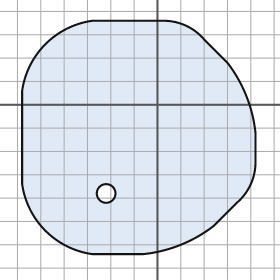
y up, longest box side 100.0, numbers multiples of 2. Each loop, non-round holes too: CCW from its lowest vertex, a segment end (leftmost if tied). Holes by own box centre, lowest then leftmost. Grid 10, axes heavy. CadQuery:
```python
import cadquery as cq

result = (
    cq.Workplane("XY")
    .moveTo(-28.0, -64.0)
    .lineTo(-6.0, -64.0)
    .threePointArc((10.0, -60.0), (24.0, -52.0))
    .lineTo(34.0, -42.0)
    .threePointArc((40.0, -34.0), (42.0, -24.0))
    .lineTo(42.0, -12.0)
    .threePointArc((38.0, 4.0), (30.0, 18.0))
    .lineTo(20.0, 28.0)
    .threePointArc((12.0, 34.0), (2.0, 36.0))
    .lineTo(-28.0, 36.0)
    .threePointArc((-48.0, 26.0), (-58.0, 6.0))
    .lineTo(-58.0, -34.0)
    .threePointArc((-48.0, -54.0), (-28.0, -64.0))
    .close()
    .moveTo(-22.0, -38.0)
    .circle(4.0)
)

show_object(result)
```